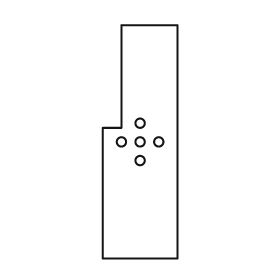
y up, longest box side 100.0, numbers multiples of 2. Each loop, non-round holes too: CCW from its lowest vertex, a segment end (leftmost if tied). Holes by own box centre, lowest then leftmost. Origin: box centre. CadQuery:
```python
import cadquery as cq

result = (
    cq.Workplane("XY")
    .moveTo(-16.0, -50.0)
    .lineTo(16.0, -50.0)
    .lineTo(16.0, 50.0)
    .lineTo(-8.0, 50.0)
    .lineTo(-8.0, 6.0)
    .lineTo(-16.0, 6.0)
    .close()
    .moveTo(0.0, -8.0)
    .circle(2.0)
    .moveTo(-8.0, 0.0)
    .circle(2.0)
    .moveTo(0.0, 0.0)
    .circle(2.0)
    .moveTo(8.0, 0.0)
    .circle(2.0)
    .moveTo(0.0, 8.0)
    .circle(2.0)
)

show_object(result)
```